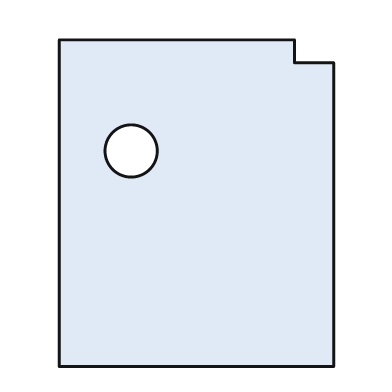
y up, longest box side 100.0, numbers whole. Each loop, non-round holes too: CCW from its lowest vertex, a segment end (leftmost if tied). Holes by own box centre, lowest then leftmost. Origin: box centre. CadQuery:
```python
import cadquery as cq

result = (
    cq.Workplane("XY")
    .moveTo(-42.0, -50.0)
    .lineTo(42.0, -50.0)
    .lineTo(42.0, 43.0)
    .lineTo(30.0, 43.0)
    .lineTo(30.0, 50.0)
    .lineTo(-42.0, 50.0)
    .close()
    .moveTo(-20.0, 16.0)
    .circle(8.0)
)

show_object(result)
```